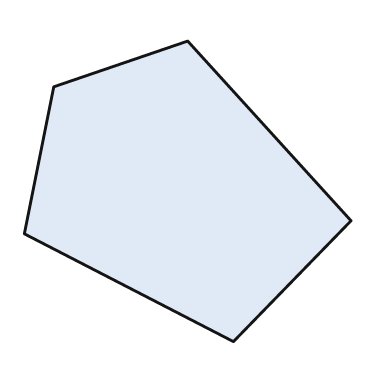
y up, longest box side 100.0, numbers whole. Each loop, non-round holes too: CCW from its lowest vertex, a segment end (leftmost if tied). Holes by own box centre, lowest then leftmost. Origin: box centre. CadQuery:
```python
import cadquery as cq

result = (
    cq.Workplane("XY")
    .moveTo(14.0, -46.0)
    .lineTo(50.0, -9.0)
    .lineTo(0.0, 46.0)
    .lineTo(-41.0, 32.0)
    .lineTo(-50.0, -13.0)
    .close()
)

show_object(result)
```